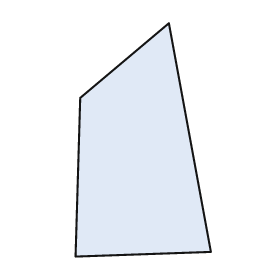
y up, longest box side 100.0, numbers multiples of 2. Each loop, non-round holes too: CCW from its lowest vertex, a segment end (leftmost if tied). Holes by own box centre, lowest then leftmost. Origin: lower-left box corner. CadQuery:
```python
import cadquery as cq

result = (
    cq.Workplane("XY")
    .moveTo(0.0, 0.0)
    .lineTo(58.0, 2.0)
    .lineTo(40.0, 100.0)
    .lineTo(2.0, 68.0)
    .close()
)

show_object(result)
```